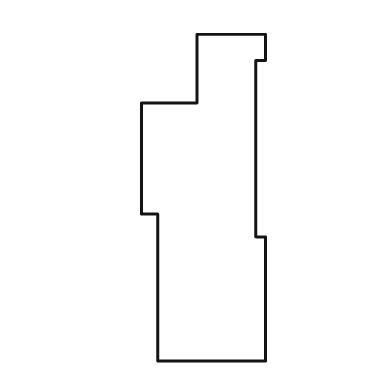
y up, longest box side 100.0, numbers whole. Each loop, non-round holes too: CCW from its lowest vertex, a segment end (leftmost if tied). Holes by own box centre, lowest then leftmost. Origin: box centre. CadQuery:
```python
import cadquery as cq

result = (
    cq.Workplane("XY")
    .moveTo(-14.0, -50.0)
    .lineTo(19.0, -50.0)
    .lineTo(19.0, -12.0)
    .lineTo(16.0, -12.0)
    .lineTo(16.0, 42.0)
    .lineTo(19.0, 42.0)
    .lineTo(19.0, 50.0)
    .lineTo(-2.0, 50.0)
    .lineTo(-2.0, 29.0)
    .lineTo(-19.0, 29.0)
    .lineTo(-19.0, -5.0)
    .lineTo(-14.0, -5.0)
    .close()
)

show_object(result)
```